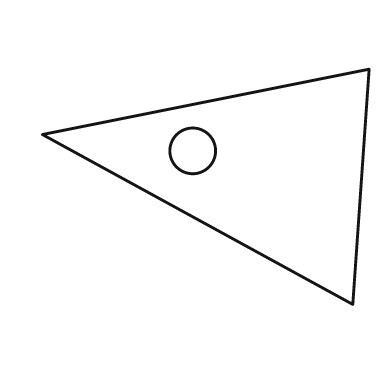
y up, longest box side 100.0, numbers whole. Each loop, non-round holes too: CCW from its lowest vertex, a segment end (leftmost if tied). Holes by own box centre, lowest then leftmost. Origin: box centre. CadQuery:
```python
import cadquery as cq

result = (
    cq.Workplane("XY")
    .moveTo(45.0, -36.0)
    .lineTo(50.0, 36.0)
    .lineTo(-50.0, 16.0)
    .close()
    .moveTo(-4.0, 11.0)
    .circle(7.0)
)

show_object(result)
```